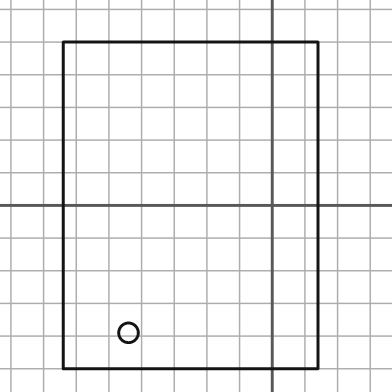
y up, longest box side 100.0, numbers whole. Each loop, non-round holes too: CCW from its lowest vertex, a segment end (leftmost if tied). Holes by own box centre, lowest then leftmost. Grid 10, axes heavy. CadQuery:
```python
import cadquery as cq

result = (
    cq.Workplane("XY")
    .moveTo(-64.0, -50.0)
    .lineTo(14.0, -50.0)
    .lineTo(14.0, 50.0)
    .lineTo(-64.0, 50.0)
    .close()
    .moveTo(-44.0, -39.0)
    .circle(3.0)
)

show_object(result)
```